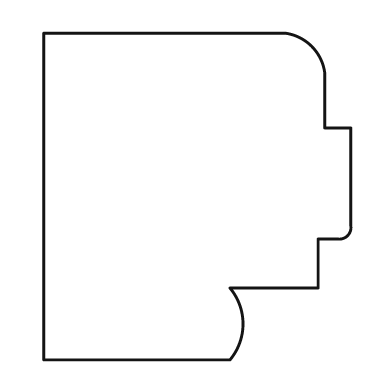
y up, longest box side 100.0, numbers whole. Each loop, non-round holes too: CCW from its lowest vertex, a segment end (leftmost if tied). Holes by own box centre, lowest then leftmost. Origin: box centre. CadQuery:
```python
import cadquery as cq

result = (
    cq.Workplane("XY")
    .moveTo(-47.0, -50.0)
    .lineTo(10.0, -50.0)
    .threePointArc((14.0, -39.0), (10.0, -28.0))
    .lineTo(37.0, -28.0)
    .lineTo(37.0, -13.0)
    .lineTo(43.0, -13.0)
    .threePointArc((46.0, -12.0), (47.0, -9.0))
    .lineTo(47.0, 21.0)
    .lineTo(39.0, 21.0)
    .lineTo(39.0, 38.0)
    .threePointArc((35.0, 46.0), (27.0, 50.0))
    .lineTo(-47.0, 50.0)
    .close()
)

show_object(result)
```